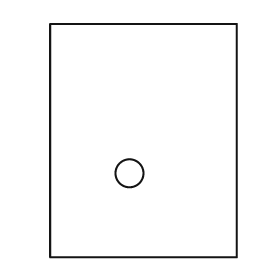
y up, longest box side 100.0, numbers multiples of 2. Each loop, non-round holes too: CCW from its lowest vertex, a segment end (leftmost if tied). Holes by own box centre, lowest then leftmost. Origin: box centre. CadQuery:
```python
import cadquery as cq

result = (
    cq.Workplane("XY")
    .moveTo(-40.0, -50.0)
    .lineTo(40.0, -50.0)
    .lineTo(40.0, 50.0)
    .lineTo(-40.0, 50.0)
    .close()
    .moveTo(-6.0, -14.0)
    .circle(6.0)
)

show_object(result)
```